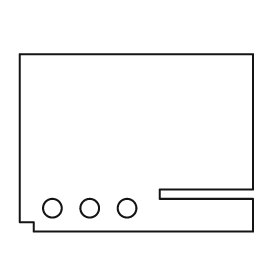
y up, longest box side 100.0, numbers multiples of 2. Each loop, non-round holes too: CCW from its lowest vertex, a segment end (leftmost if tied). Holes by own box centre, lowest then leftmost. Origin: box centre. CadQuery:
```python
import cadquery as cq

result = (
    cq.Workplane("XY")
    .moveTo(-44.0, -38.0)
    .lineTo(50.0, -38.0)
    .lineTo(50.0, -24.0)
    .lineTo(10.0, -24.0)
    .lineTo(10.0, -20.0)
    .lineTo(50.0, -20.0)
    .lineTo(50.0, 38.0)
    .lineTo(-50.0, 38.0)
    .lineTo(-50.0, -34.0)
    .lineTo(-44.0, -34.0)
    .close()
    .moveTo(-36.0, -28.0)
    .circle(4.0)
    .moveTo(-20.0, -28.0)
    .circle(4.0)
    .moveTo(-4.0, -28.0)
    .circle(4.0)
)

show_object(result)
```